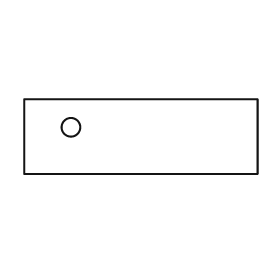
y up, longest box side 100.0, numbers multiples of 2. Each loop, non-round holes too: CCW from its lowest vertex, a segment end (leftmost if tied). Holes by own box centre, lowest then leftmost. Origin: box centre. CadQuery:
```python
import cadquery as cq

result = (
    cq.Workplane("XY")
    .moveTo(-50.0, -16.0)
    .lineTo(50.0, -16.0)
    .lineTo(50.0, 16.0)
    .lineTo(-50.0, 16.0)
    .close()
    .moveTo(-30.0, 4.0)
    .circle(4.0)
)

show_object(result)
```